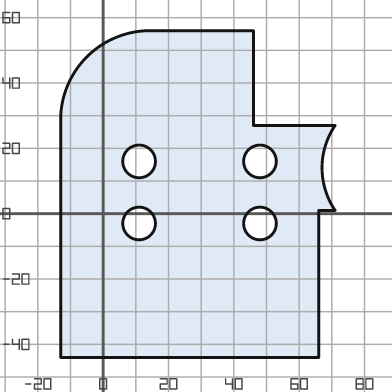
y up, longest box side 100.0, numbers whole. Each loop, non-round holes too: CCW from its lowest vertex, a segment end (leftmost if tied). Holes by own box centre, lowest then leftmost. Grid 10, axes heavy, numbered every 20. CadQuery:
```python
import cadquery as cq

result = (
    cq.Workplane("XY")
    .moveTo(-13.0, -44.0)
    .lineTo(66.0, -44.0)
    .lineTo(66.0, 1.0)
    .lineTo(71.0, 1.0)
    .threePointArc((67.0, 14.0), (71.0, 27.0))
    .lineTo(46.0, 27.0)
    .lineTo(46.0, 56.0)
    .lineTo(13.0, 56.0)
    .threePointArc((-5.0, 48.0), (-13.0, 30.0))
    .close()
    .moveTo(11.0, -3.0)
    .circle(5.0)
    .moveTo(48.0, -3.0)
    .circle(5.0)
    .moveTo(11.0, 16.0)
    .circle(5.0)
    .moveTo(48.0, 16.0)
    .circle(5.0)
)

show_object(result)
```